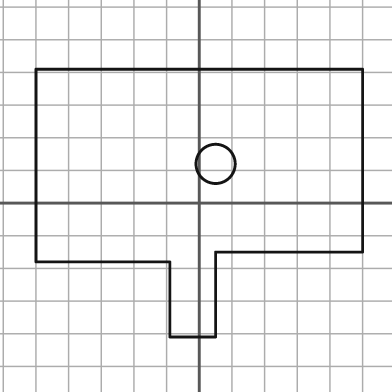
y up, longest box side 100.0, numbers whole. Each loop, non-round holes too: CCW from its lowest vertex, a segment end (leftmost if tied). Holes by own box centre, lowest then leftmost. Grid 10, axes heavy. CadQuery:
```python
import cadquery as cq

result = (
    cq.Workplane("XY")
    .moveTo(-9.0, -41.0)
    .lineTo(5.0, -41.0)
    .lineTo(5.0, -15.0)
    .lineTo(50.0, -15.0)
    .lineTo(50.0, 41.0)
    .lineTo(-50.0, 41.0)
    .lineTo(-50.0, -18.0)
    .lineTo(-9.0, -18.0)
    .close()
    .moveTo(5.0, 12.0)
    .circle(6.0)
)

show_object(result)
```